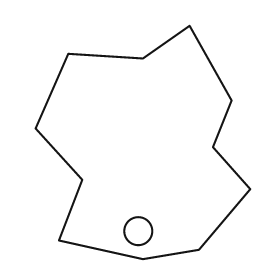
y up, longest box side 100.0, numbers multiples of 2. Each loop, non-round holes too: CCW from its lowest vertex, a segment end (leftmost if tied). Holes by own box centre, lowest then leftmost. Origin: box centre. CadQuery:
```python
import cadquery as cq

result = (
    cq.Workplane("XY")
    .moveTo(0.0, -50.0)
    .lineTo(24.0, -46.0)
    .lineTo(46.0, -20.0)
    .lineTo(30.0, -2.0)
    .lineTo(38.0, 18.0)
    .lineTo(20.0, 50.0)
    .lineTo(0.0, 36.0)
    .lineTo(-32.0, 38.0)
    .lineTo(-46.0, 6.0)
    .lineTo(-26.0, -16.0)
    .lineTo(-36.0, -42.0)
    .close()
    .moveTo(-2.0, -38.0)
    .circle(6.0)
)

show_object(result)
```